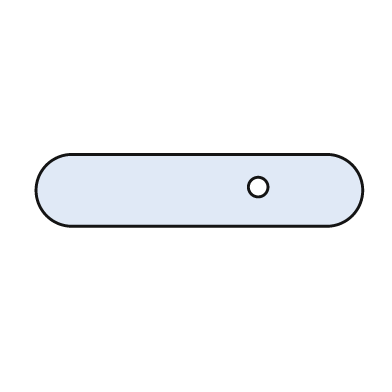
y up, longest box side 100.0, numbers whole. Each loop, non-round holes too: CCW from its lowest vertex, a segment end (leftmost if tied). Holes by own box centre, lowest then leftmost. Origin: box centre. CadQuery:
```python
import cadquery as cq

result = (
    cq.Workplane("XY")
    .moveTo(-39.0, -11.0)
    .lineTo(39.0, -11.0)
    .threePointArc((50.0, 0.0), (39.0, 11.0))
    .lineTo(-39.0, 11.0)
    .threePointArc((-50.0, 0.0), (-39.0, -11.0))
    .close()
    .moveTo(18.0, 1.0)
    .circle(3.0)
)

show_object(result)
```